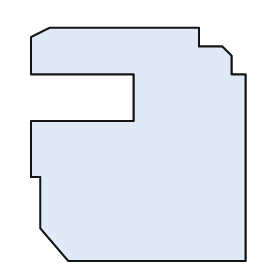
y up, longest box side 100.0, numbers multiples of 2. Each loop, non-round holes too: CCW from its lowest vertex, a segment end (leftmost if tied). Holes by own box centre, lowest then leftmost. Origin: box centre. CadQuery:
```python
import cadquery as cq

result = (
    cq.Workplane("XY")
    .moveTo(-30.0, -50.0)
    .lineTo(46.0, -50.0)
    .lineTo(46.0, 30.0)
    .lineTo(40.0, 30.0)
    .lineTo(40.0, 38.0)
    .lineTo(36.0, 42.0)
    .lineTo(26.0, 42.0)
    .lineTo(26.0, 50.0)
    .lineTo(-38.0, 50.0)
    .lineTo(-46.0, 46.0)
    .lineTo(-46.0, 30.0)
    .lineTo(-2.0, 30.0)
    .lineTo(-2.0, 10.0)
    .lineTo(-46.0, 10.0)
    .lineTo(-46.0, -14.0)
    .lineTo(-42.0, -14.0)
    .lineTo(-42.0, -36.0)
    .close()
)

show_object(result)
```